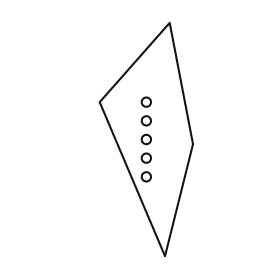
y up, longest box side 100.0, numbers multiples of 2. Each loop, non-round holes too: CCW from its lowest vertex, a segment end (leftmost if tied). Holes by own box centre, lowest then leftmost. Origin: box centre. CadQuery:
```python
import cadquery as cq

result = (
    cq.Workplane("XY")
    .moveTo(8.0, -50.0)
    .lineTo(20.0, -2.0)
    .lineTo(10.0, 50.0)
    .lineTo(-20.0, 16.0)
    .close()
    .moveTo(0.0, -16.0)
    .circle(2.0)
    .moveTo(0.0, -8.0)
    .circle(2.0)
    .moveTo(0.0, 0.0)
    .circle(2.0)
    .moveTo(0.0, 8.0)
    .circle(2.0)
    .moveTo(0.0, 16.0)
    .circle(2.0)
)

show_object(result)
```